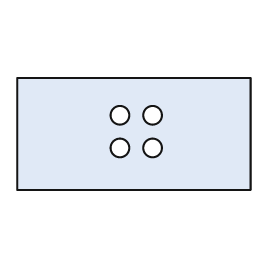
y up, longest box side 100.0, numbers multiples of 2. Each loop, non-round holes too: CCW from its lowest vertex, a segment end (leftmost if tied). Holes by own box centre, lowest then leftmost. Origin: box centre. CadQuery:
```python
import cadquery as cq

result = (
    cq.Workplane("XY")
    .moveTo(-50.0, -24.0)
    .lineTo(50.0, -24.0)
    .lineTo(50.0, 24.0)
    .lineTo(-50.0, 24.0)
    .close()
    .moveTo(-6.0, -6.0)
    .circle(4.0)
    .moveTo(8.0, -6.0)
    .circle(4.0)
    .moveTo(-6.0, 8.0)
    .circle(4.0)
    .moveTo(8.0, 8.0)
    .circle(4.0)
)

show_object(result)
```